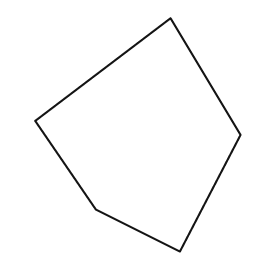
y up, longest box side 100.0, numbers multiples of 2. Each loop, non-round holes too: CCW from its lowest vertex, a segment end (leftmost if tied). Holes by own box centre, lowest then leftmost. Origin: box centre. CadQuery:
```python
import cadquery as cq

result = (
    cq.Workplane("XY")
    .moveTo(18.0, -50.0)
    .lineTo(44.0, 0.0)
    .lineTo(14.0, 50.0)
    .lineTo(-44.0, 6.0)
    .lineTo(-18.0, -32.0)
    .close()
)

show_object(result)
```